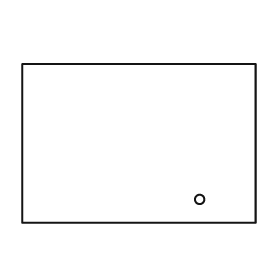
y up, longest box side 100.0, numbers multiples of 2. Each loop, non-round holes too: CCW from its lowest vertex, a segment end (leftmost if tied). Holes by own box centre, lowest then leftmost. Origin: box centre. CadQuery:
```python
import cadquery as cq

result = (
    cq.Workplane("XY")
    .moveTo(-50.0, -34.0)
    .lineTo(50.0, -34.0)
    .lineTo(50.0, 34.0)
    .lineTo(-50.0, 34.0)
    .close()
    .moveTo(26.0, -24.0)
    .circle(2.0)
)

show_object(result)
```